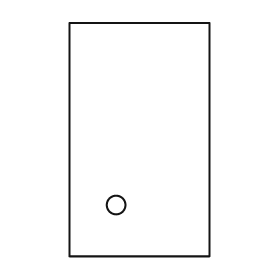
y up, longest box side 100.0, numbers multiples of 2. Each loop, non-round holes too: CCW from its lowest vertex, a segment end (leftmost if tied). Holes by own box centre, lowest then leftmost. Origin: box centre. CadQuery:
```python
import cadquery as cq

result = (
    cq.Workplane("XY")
    .moveTo(-30.0, -50.0)
    .lineTo(30.0, -50.0)
    .lineTo(30.0, 50.0)
    .lineTo(-30.0, 50.0)
    .close()
    .moveTo(-10.0, -28.0)
    .circle(4.0)
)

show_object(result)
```